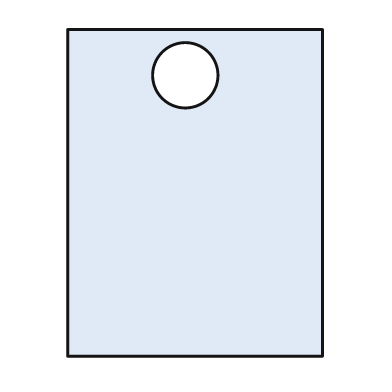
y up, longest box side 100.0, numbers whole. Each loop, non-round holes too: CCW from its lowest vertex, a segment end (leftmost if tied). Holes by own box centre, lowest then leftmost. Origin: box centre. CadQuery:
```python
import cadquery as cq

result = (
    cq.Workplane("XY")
    .moveTo(-39.0, -50.0)
    .lineTo(39.0, -50.0)
    .lineTo(39.0, 50.0)
    .lineTo(-39.0, 50.0)
    .close()
    .moveTo(-3.0, 36.0)
    .circle(10.0)
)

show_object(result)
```